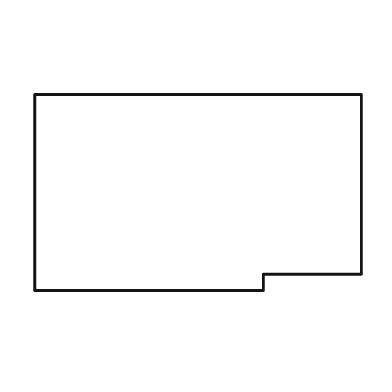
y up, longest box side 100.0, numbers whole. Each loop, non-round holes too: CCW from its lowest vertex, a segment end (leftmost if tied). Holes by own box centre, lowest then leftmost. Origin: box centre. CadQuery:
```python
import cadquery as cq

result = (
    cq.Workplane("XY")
    .moveTo(-50.0, -30.0)
    .lineTo(20.0, -30.0)
    .lineTo(20.0, -25.0)
    .lineTo(50.0, -25.0)
    .lineTo(50.0, 30.0)
    .lineTo(-50.0, 30.0)
    .close()
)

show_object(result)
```